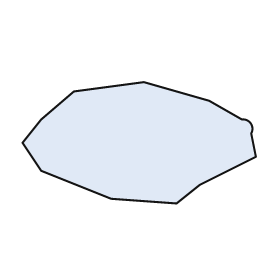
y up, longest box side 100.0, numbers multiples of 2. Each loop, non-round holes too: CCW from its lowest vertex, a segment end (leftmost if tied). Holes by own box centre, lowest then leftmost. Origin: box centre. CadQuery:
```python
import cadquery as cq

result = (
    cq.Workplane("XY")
    .moveTo(16.0, -26.0)
    .lineTo(26.0, -18.0)
    .lineTo(50.0, -6.0)
    .lineTo(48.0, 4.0)
    .threePointArc((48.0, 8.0), (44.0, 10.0))
    .lineTo(30.0, 18.0)
    .lineTo(2.0, 26.0)
    .lineTo(-28.0, 22.0)
    .lineTo(-42.0, 10.0)
    .lineTo(-50.0, 0.0)
    .lineTo(-42.0, -12.0)
    .lineTo(-12.0, -24.0)
    .close()
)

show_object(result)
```